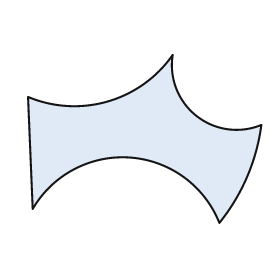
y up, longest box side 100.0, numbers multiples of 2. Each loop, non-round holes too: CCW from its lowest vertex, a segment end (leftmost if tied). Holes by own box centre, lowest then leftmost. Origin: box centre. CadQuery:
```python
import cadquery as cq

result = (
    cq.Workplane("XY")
    .moveTo(32.0, -36.0)
    .threePointArc((44.0, -16.0), (50.0, 6.0))
    .threePointArc((22.0, 10.0), (12.0, 36.0))
    .threePointArc((-16.0, 16.0), (-50.0, 18.0))
    .lineTo(-48.0, -30.0)
    .threePointArc((-6.0, -8.0), (32.0, -36.0))
    .close()
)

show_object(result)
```